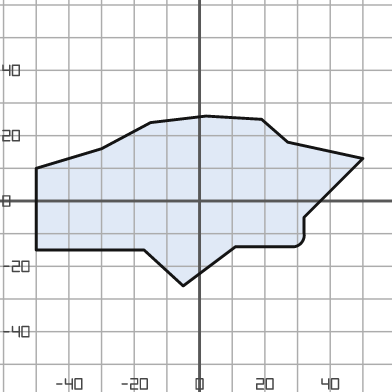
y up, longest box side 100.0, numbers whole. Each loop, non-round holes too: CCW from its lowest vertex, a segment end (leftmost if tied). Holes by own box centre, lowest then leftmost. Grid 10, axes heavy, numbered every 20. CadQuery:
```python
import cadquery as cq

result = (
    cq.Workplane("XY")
    .moveTo(-5.0, -26.0)
    .lineTo(11.0, -14.0)
    .lineTo(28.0, -14.0)
    .threePointArc((31.0, -13.0), (32.0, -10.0))
    .lineTo(32.0, -5.0)
    .lineTo(50.0, 13.0)
    .lineTo(27.0, 18.0)
    .lineTo(19.0, 25.0)
    .lineTo(2.0, 26.0)
    .lineTo(-15.0, 24.0)
    .lineTo(-30.0, 16.0)
    .lineTo(-50.0, 10.0)
    .lineTo(-50.0, -15.0)
    .lineTo(-17.0, -15.0)
    .close()
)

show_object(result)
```